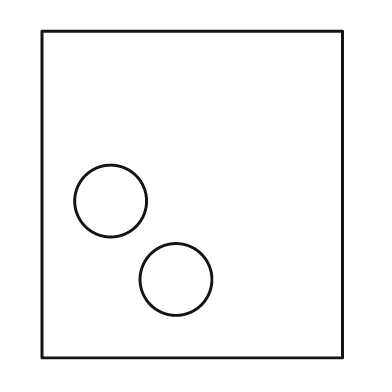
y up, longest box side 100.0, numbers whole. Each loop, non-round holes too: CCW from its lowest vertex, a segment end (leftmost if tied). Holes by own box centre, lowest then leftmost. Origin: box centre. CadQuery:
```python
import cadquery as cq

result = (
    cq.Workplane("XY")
    .moveTo(-46.0, -50.0)
    .lineTo(46.0, -50.0)
    .lineTo(46.0, 50.0)
    .lineTo(-46.0, 50.0)
    .close()
    .moveTo(-5.0, -26.0)
    .circle(11.0)
    .moveTo(-25.0, -2.0)
    .circle(11.0)
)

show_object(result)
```